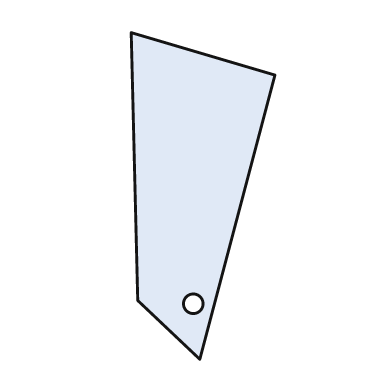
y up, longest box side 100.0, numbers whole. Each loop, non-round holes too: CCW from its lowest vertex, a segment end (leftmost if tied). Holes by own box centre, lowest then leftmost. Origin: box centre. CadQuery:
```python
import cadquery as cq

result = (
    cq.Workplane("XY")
    .moveTo(-1.0, -50.0)
    .lineTo(22.0, 37.0)
    .lineTo(-22.0, 50.0)
    .lineTo(-20.0, -32.0)
    .close()
    .moveTo(-3.0, -33.0)
    .circle(3.0)
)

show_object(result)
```